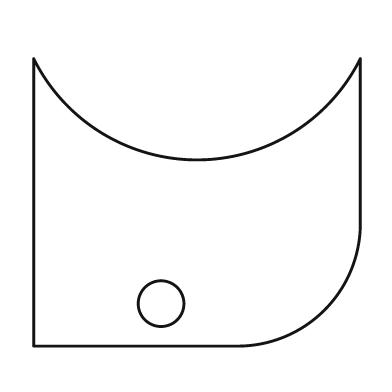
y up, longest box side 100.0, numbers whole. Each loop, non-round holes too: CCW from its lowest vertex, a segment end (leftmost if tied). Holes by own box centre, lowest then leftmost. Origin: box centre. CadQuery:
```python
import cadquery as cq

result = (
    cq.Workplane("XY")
    .moveTo(-50.0, -44.0)
    .lineTo(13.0, -44.0)
    .threePointArc((39.0, -33.0), (50.0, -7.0))
    .lineTo(50.0, 44.0)
    .threePointArc((0.0, 13.0), (-50.0, 44.0))
    .close()
    .moveTo(-11.0, -31.0)
    .circle(7.0)
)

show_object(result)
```